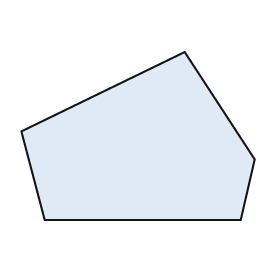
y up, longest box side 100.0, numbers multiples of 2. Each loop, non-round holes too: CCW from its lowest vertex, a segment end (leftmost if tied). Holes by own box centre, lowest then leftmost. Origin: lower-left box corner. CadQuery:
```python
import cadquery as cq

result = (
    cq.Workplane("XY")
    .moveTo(10.0, 0.0)
    .lineTo(94.0, 0.0)
    .lineTo(100.0, 26.0)
    .lineTo(70.0, 72.0)
    .lineTo(0.0, 38.0)
    .close()
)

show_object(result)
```